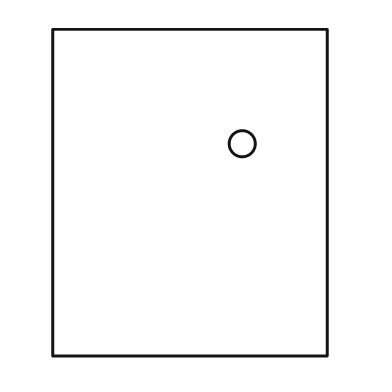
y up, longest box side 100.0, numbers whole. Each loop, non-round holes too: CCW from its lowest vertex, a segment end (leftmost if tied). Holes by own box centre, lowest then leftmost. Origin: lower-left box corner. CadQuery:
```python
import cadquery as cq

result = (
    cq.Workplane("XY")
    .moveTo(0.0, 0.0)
    .lineTo(84.0, 0.0)
    .lineTo(84.0, 100.0)
    .lineTo(0.0, 100.0)
    .close()
    .moveTo(58.0, 65.0)
    .circle(4.0)
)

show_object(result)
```